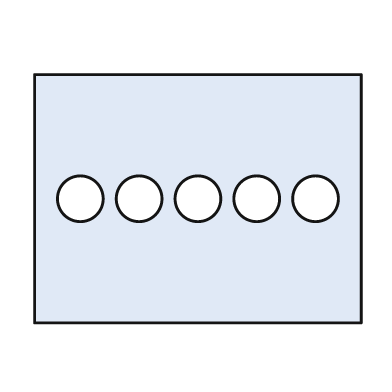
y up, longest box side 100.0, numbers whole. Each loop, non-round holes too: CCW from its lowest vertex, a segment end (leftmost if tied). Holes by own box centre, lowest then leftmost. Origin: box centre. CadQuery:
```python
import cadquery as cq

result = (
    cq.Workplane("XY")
    .moveTo(-50.0, -38.0)
    .lineTo(50.0, -38.0)
    .lineTo(50.0, 38.0)
    .lineTo(-50.0, 38.0)
    .close()
    .moveTo(-36.0, 0.0)
    .circle(7.0)
    .moveTo(-18.0, 0.0)
    .circle(7.0)
    .moveTo(0.0, 0.0)
    .circle(7.0)
    .moveTo(18.0, 0.0)
    .circle(7.0)
    .moveTo(36.0, 0.0)
    .circle(7.0)
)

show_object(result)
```